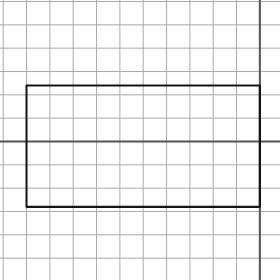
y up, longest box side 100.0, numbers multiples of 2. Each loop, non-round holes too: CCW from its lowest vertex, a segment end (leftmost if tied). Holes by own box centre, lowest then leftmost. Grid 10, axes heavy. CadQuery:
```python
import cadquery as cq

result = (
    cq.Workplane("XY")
    .moveTo(-100.0, -28.0)
    .lineTo(0.0, -28.0)
    .lineTo(0.0, 24.0)
    .lineTo(-100.0, 24.0)
    .close()
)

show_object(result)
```